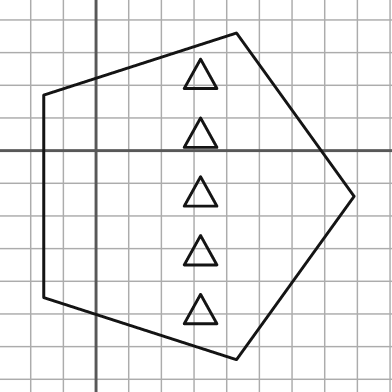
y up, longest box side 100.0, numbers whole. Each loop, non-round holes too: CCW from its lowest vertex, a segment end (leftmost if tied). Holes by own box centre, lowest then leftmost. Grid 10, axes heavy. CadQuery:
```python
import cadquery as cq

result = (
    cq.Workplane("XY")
    .moveTo(43.0, -64.0)
    .lineTo(79.0, -14.0)
    .lineTo(43.0, 36.0)
    .lineTo(-16.0, 17.0)
    .lineTo(-16.0, -45.0)
    .close()
    .moveTo(27.0, -53.0)
    .lineTo(37.0, -53.0)
    .lineTo(32.0, -44.0)
    .close()
    .moveTo(27.0, -35.0)
    .lineTo(37.0, -35.0)
    .lineTo(32.0, -26.0)
    .close()
    .moveTo(27.0, -17.0)
    .lineTo(37.0, -17.0)
    .lineTo(32.0, -8.0)
    .close()
    .moveTo(27.0, 1.0)
    .lineTo(37.0, 1.0)
    .lineTo(32.0, 10.0)
    .close()
    .moveTo(27.0, 19.0)
    .lineTo(37.0, 19.0)
    .lineTo(32.0, 28.0)
    .close()
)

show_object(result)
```